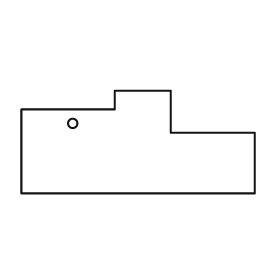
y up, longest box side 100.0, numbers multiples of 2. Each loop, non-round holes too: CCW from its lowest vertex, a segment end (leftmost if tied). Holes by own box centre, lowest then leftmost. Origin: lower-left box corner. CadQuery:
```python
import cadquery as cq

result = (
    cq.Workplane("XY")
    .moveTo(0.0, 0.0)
    .lineTo(100.0, 0.0)
    .lineTo(100.0, 26.0)
    .lineTo(64.0, 26.0)
    .lineTo(64.0, 44.0)
    .lineTo(40.0, 44.0)
    .lineTo(40.0, 36.0)
    .lineTo(0.0, 36.0)
    .close()
    .moveTo(22.0, 30.0)
    .circle(2.0)
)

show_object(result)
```